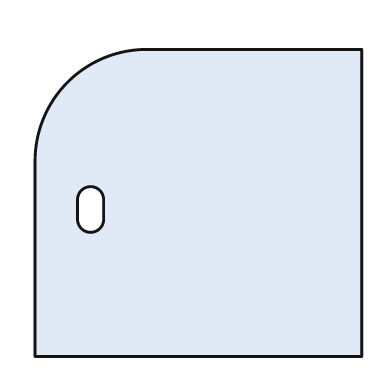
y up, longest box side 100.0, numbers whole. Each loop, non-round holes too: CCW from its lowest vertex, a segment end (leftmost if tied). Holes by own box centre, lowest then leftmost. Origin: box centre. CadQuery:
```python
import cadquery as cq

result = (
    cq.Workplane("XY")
    .moveTo(-50.0, -47.0)
    .lineTo(50.0, -47.0)
    .lineTo(50.0, 47.0)
    .lineTo(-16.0, 47.0)
    .threePointArc((-40.0, 37.0), (-50.0, 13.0))
    .close()
    .moveTo(-37.0, -5.0)
    .threePointArc((-33.0, -9.0), (-29.0, -5.0))
    .lineTo(-29.0, 1.0)
    .threePointArc((-33.0, 5.0), (-37.0, 1.0))
    .close()
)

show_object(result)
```